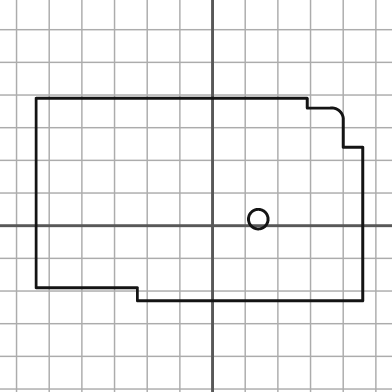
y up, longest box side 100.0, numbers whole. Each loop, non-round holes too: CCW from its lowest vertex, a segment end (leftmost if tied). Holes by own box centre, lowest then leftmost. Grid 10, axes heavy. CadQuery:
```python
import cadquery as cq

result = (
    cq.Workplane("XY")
    .moveTo(-23.0, -23.0)
    .lineTo(46.0, -23.0)
    .lineTo(46.0, 24.0)
    .lineTo(40.0, 24.0)
    .lineTo(40.0, 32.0)
    .threePointArc((39.0, 35.0), (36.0, 36.0))
    .lineTo(29.0, 36.0)
    .lineTo(29.0, 39.0)
    .lineTo(-54.0, 39.0)
    .lineTo(-54.0, -19.0)
    .lineTo(-23.0, -19.0)
    .close()
    .moveTo(14.0, 2.0)
    .circle(3.0)
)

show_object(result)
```